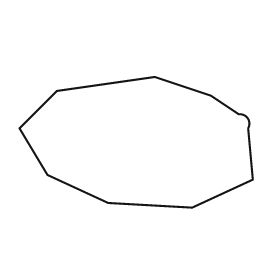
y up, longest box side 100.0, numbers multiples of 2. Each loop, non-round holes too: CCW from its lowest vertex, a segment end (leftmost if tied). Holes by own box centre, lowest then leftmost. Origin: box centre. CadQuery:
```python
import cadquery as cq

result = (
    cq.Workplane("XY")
    .moveTo(24.0, -28.0)
    .lineTo(50.0, -16.0)
    .lineTo(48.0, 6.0)
    .threePointArc((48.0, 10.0), (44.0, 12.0))
    .lineTo(32.0, 20.0)
    .lineTo(8.0, 28.0)
    .lineTo(-34.0, 22.0)
    .lineTo(-50.0, 6.0)
    .lineTo(-38.0, -14.0)
    .lineTo(-12.0, -26.0)
    .close()
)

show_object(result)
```